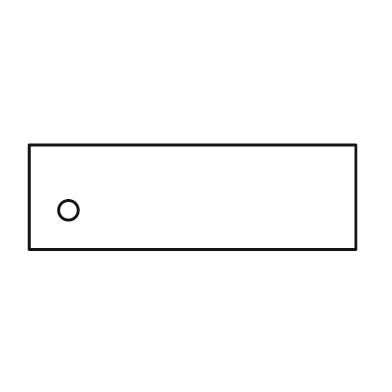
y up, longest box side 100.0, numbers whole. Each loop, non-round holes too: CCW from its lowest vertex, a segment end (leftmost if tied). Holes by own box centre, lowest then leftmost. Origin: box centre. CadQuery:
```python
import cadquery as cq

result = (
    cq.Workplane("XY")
    .moveTo(-50.0, -16.0)
    .lineTo(50.0, -16.0)
    .lineTo(50.0, 16.0)
    .lineTo(-50.0, 16.0)
    .close()
    .moveTo(-38.0, -4.0)
    .circle(3.0)
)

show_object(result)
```